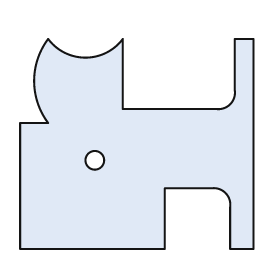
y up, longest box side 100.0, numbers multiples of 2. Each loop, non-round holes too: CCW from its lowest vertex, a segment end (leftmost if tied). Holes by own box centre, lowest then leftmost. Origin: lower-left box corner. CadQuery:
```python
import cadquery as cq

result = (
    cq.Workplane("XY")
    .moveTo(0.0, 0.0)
    .lineTo(62.0, 0.0)
    .lineTo(62.0, 26.0)
    .lineTo(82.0, 26.0)
    .threePointArc((88.0, 24.0), (90.0, 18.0))
    .lineTo(90.0, 0.0)
    .lineTo(100.0, 0.0)
    .lineTo(100.0, 90.0)
    .lineTo(92.0, 90.0)
    .lineTo(92.0, 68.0)
    .threePointArc((90.0, 62.0), (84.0, 60.0))
    .lineTo(44.0, 60.0)
    .lineTo(44.0, 90.0)
    .threePointArc((28.0, 82.0), (12.0, 90.0))
    .threePointArc((6.0, 72.0), (12.0, 54.0))
    .lineTo(0.0, 54.0)
    .close()
    .moveTo(32.0, 38.0)
    .circle(4.0)
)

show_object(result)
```